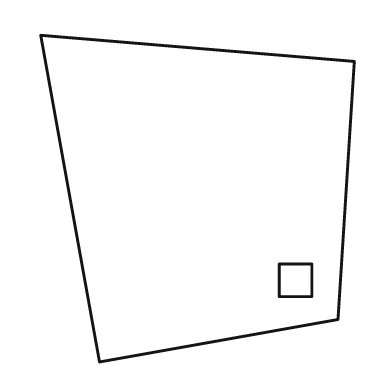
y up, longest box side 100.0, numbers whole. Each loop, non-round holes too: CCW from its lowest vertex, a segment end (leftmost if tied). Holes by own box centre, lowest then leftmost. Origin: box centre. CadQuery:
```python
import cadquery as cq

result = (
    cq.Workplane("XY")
    .moveTo(-30.0, -50.0)
    .lineTo(43.0, -37.0)
    .lineTo(48.0, 42.0)
    .lineTo(-48.0, 50.0)
    .close()
    .moveTo(25.0, -30.0)
    .lineTo(35.0, -30.0)
    .lineTo(35.0, -20.0)
    .lineTo(25.0, -20.0)
    .close()
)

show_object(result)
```